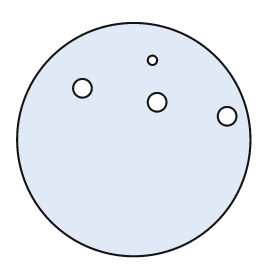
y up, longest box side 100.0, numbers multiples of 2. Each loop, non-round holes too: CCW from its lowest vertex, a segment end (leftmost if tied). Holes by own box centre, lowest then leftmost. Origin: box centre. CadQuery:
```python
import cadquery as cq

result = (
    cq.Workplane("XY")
    .moveTo(0.0, 0.0)
    .circle(50.0)
    .moveTo(40.0, 10.0)
    .circle(4.0)
    .moveTo(10.0, 16.0)
    .circle(4.0)
    .moveTo(-22.0, 22.0)
    .circle(4.0)
    .moveTo(8.0, 34.0)
    .circle(2.0)
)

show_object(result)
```